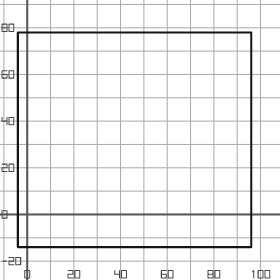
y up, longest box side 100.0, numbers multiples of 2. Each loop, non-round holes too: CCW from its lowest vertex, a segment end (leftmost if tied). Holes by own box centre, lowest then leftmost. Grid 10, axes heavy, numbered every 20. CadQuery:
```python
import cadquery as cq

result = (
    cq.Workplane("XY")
    .moveTo(-4.0, -14.0)
    .lineTo(96.0, -14.0)
    .lineTo(96.0, 78.0)
    .lineTo(-4.0, 78.0)
    .close()
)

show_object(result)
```